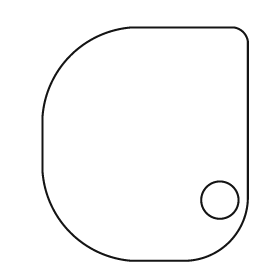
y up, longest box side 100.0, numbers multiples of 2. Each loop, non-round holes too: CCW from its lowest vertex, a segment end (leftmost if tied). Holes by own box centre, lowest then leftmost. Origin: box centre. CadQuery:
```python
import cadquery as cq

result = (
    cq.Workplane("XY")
    .moveTo(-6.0, -50.0)
    .lineTo(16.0, -50.0)
    .threePointArc((36.0, -42.0), (44.0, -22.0))
    .lineTo(44.0, 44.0)
    .threePointArc((42.0, 48.0), (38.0, 50.0))
    .lineTo(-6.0, 50.0)
    .threePointArc((-32.0, 38.0), (-44.0, 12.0))
    .lineTo(-44.0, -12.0)
    .threePointArc((-32.0, -38.0), (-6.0, -50.0))
    .close()
    .moveTo(32.0, -24.0)
    .circle(8.0)
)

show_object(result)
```